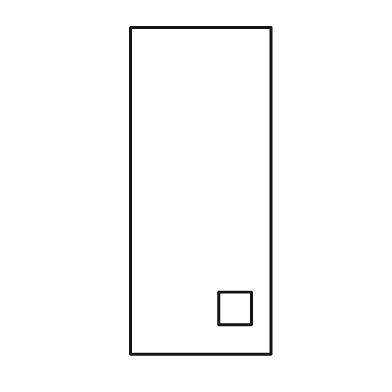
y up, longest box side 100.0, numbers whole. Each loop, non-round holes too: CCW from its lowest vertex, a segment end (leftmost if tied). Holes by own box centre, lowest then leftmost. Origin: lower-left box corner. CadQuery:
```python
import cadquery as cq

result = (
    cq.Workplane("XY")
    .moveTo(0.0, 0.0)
    .lineTo(43.0, 0.0)
    .lineTo(43.0, 100.0)
    .lineTo(0.0, 100.0)
    .close()
    .moveTo(27.0, 9.0)
    .lineTo(37.0, 9.0)
    .lineTo(37.0, 19.0)
    .lineTo(27.0, 19.0)
    .close()
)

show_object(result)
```